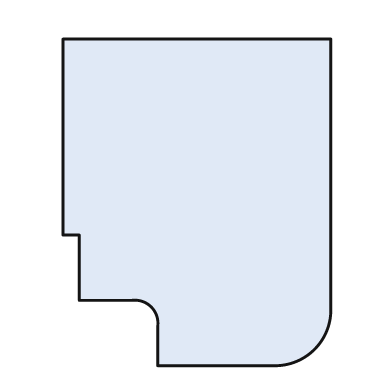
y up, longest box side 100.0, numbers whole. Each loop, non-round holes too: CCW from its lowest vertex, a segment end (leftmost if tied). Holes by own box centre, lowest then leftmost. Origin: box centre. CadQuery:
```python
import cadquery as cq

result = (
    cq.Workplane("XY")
    .moveTo(-12.0, -50.0)
    .lineTo(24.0, -50.0)
    .threePointArc((36.0, -45.0), (41.0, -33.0))
    .lineTo(41.0, 50.0)
    .lineTo(-41.0, 50.0)
    .lineTo(-41.0, -10.0)
    .lineTo(-36.0, -10.0)
    .lineTo(-36.0, -30.0)
    .lineTo(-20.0, -30.0)
    .threePointArc((-14.0, -32.0), (-12.0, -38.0))
    .close()
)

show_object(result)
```